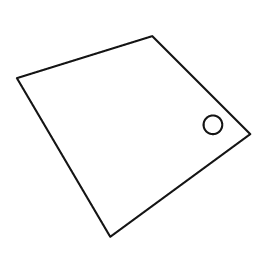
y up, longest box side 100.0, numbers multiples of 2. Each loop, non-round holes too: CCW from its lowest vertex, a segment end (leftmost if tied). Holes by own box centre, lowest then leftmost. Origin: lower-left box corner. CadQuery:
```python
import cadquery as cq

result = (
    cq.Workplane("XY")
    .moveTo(40.0, 0.0)
    .lineTo(100.0, 44.0)
    .lineTo(58.0, 86.0)
    .lineTo(0.0, 68.0)
    .close()
    .moveTo(84.0, 48.0)
    .circle(4.0)
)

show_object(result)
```